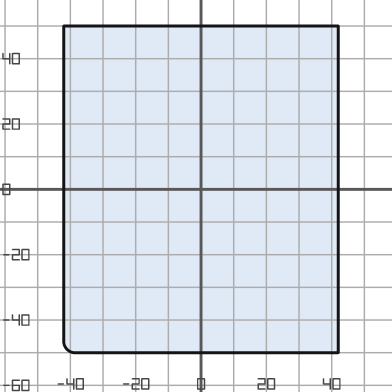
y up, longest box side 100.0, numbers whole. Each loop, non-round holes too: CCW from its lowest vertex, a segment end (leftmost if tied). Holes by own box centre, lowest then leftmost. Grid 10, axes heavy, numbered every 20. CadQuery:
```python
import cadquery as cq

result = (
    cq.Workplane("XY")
    .moveTo(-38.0, -50.0)
    .lineTo(42.0, -50.0)
    .lineTo(42.0, 50.0)
    .lineTo(-42.0, 50.0)
    .lineTo(-42.0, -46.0)
    .threePointArc((-41.0, -49.0), (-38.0, -50.0))
    .close()
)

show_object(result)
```